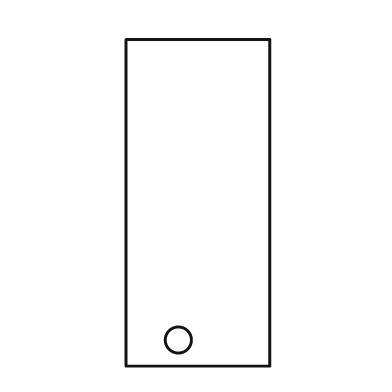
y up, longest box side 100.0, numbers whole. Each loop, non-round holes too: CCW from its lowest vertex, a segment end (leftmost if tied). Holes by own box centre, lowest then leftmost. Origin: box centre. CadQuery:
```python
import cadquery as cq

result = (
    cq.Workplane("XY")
    .moveTo(-22.0, -50.0)
    .lineTo(22.0, -50.0)
    .lineTo(22.0, 50.0)
    .lineTo(-22.0, 50.0)
    .close()
    .moveTo(-6.0, -42.0)
    .circle(4.0)
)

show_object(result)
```